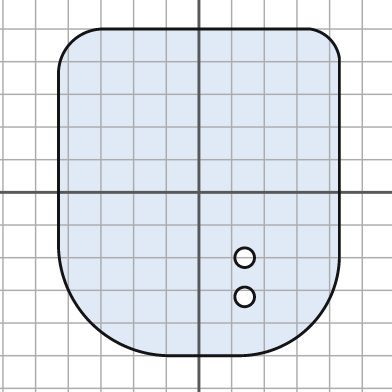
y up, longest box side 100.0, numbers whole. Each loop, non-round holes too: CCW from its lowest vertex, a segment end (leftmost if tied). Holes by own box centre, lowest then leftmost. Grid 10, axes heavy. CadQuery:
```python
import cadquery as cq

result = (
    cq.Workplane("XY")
    .moveTo(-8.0, -50.0)
    .lineTo(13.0, -50.0)
    .threePointArc((34.0, -41.0), (43.0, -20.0))
    .lineTo(43.0, 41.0)
    .threePointArc((40.0, 47.0), (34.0, 50.0))
    .lineTo(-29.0, 50.0)
    .threePointArc((-39.0, 46.0), (-43.0, 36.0))
    .lineTo(-43.0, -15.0)
    .threePointArc((-33.0, -40.0), (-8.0, -50.0))
    .close()
    .moveTo(14.0, -32.0)
    .circle(3.0)
    .moveTo(14.0, -20.0)
    .circle(3.0)
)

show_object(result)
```